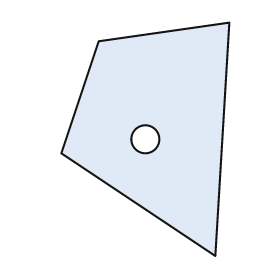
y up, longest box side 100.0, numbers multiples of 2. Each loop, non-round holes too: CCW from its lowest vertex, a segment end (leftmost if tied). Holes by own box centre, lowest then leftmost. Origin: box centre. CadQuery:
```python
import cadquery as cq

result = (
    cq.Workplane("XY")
    .moveTo(30.0, -50.0)
    .lineTo(36.0, 50.0)
    .lineTo(-20.0, 42.0)
    .lineTo(-36.0, -6.0)
    .close()
    .moveTo(0.0, 0.0)
    .circle(6.0)
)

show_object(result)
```